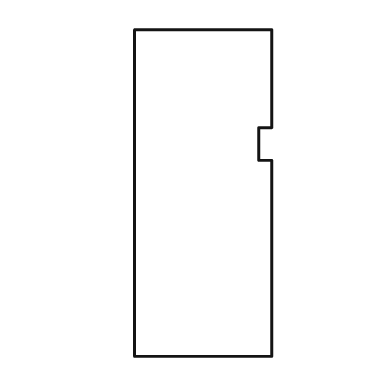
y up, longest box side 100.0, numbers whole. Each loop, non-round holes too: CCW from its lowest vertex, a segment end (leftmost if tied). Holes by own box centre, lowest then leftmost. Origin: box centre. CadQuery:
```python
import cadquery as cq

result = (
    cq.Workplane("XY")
    .moveTo(-21.0, -50.0)
    .lineTo(21.0, -50.0)
    .lineTo(21.0, 10.0)
    .lineTo(17.0, 10.0)
    .lineTo(17.0, 20.0)
    .lineTo(21.0, 20.0)
    .lineTo(21.0, 50.0)
    .lineTo(-21.0, 50.0)
    .close()
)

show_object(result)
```